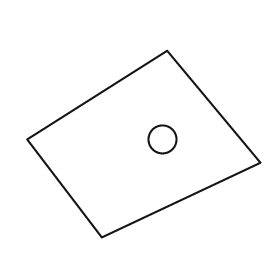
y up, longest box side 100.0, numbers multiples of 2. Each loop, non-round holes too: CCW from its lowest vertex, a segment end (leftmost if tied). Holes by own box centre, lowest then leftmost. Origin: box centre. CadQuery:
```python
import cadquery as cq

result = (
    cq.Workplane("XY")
    .moveTo(-18.0, -40.0)
    .lineTo(50.0, -8.0)
    .lineTo(10.0, 40.0)
    .lineTo(-50.0, 2.0)
    .close()
    .moveTo(8.0, 2.0)
    .circle(6.0)
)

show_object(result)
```